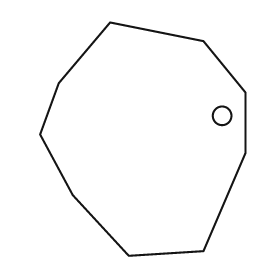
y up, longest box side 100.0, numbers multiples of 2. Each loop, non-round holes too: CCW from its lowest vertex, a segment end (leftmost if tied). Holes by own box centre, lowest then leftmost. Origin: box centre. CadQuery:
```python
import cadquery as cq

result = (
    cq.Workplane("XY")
    .moveTo(-6.0, -50.0)
    .lineTo(26.0, -48.0)
    .lineTo(44.0, -6.0)
    .lineTo(44.0, 20.0)
    .lineTo(26.0, 42.0)
    .lineTo(-14.0, 50.0)
    .lineTo(-36.0, 24.0)
    .lineTo(-44.0, 2.0)
    .lineTo(-30.0, -24.0)
    .close()
    .moveTo(34.0, 10.0)
    .circle(4.0)
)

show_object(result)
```